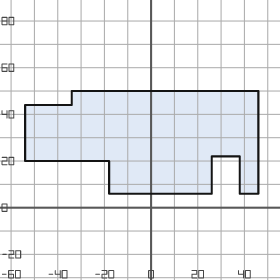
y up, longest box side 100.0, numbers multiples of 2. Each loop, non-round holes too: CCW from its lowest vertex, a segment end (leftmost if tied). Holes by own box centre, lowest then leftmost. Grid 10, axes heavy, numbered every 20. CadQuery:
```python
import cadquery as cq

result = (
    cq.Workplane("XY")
    .moveTo(-18.0, 6.0)
    .lineTo(26.0, 6.0)
    .lineTo(26.0, 22.0)
    .lineTo(38.0, 22.0)
    .lineTo(38.0, 6.0)
    .lineTo(46.0, 6.0)
    .lineTo(46.0, 50.0)
    .lineTo(-34.0, 50.0)
    .lineTo(-34.0, 44.0)
    .lineTo(-54.0, 44.0)
    .lineTo(-54.0, 20.0)
    .lineTo(-18.0, 20.0)
    .close()
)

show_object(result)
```